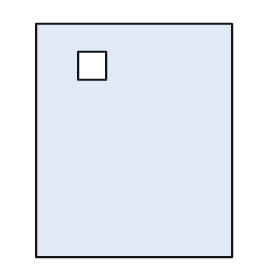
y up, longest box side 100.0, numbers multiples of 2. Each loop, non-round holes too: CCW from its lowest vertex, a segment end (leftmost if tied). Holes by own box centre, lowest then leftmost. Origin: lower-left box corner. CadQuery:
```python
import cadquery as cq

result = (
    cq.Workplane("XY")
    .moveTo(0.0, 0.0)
    .lineTo(84.0, 0.0)
    .lineTo(84.0, 100.0)
    .lineTo(0.0, 100.0)
    .close()
    .moveTo(18.0, 76.0)
    .lineTo(30.0, 76.0)
    .lineTo(30.0, 88.0)
    .lineTo(18.0, 88.0)
    .close()
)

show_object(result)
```